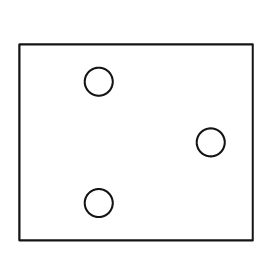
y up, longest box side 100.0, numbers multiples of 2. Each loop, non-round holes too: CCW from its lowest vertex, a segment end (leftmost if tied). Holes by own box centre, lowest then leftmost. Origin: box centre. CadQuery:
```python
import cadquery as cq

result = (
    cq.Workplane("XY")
    .moveTo(-50.0, -42.0)
    .lineTo(50.0, -42.0)
    .lineTo(50.0, 42.0)
    .lineTo(-50.0, 42.0)
    .close()
    .moveTo(-16.0, -26.0)
    .circle(6.0)
    .moveTo(32.0, 0.0)
    .circle(6.0)
    .moveTo(-16.0, 26.0)
    .circle(6.0)
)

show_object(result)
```